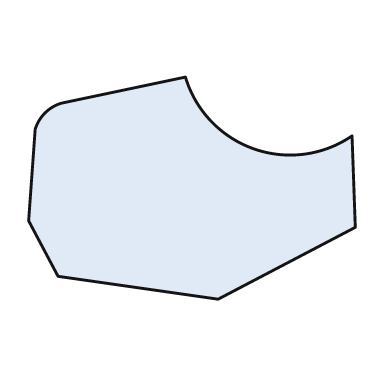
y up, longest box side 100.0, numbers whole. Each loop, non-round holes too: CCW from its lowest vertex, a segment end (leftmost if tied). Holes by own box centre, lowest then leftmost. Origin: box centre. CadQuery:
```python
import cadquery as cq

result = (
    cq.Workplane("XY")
    .moveTo(8.0, -34.0)
    .lineTo(50.0, -12.0)
    .lineTo(49.0, 16.0)
    .threePointArc((19.0, 12.0), (-2.0, 34.0))
    .lineTo(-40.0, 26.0)
    .threePointArc((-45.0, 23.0), (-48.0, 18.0))
    .lineTo(-50.0, -10.0)
    .lineTo(-41.0, -27.0)
    .close()
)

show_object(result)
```